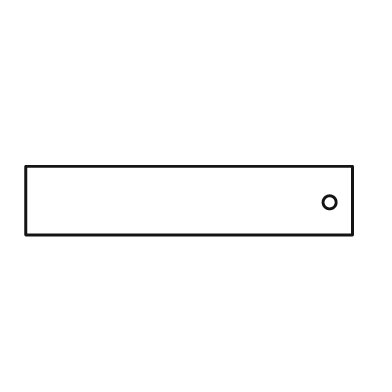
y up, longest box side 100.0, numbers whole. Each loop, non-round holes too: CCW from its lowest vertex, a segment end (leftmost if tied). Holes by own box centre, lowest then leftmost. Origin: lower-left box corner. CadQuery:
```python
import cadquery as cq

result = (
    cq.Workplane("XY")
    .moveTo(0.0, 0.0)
    .lineTo(100.0, 0.0)
    .lineTo(100.0, 21.0)
    .lineTo(0.0, 21.0)
    .close()
    .moveTo(93.0, 10.0)
    .circle(2.0)
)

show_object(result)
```